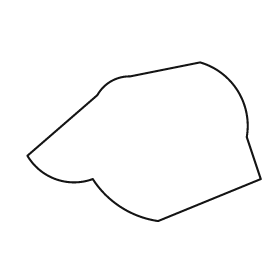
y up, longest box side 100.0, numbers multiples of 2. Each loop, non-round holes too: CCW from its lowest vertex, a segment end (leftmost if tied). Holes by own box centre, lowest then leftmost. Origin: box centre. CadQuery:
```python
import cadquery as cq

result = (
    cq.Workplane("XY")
    .moveTo(6.0, -34.0)
    .lineTo(50.0, -16.0)
    .lineTo(44.0, 2.0)
    .threePointArc((40.0, 22.0), (24.0, 34.0))
    .lineTo(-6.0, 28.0)
    .threePointArc((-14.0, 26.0), (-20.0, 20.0))
    .lineTo(-50.0, -6.0)
    .threePointArc((-38.0, -16.0), (-22.0, -16.0))
    .threePointArc((-10.0, -28.0), (6.0, -34.0))
    .close()
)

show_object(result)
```